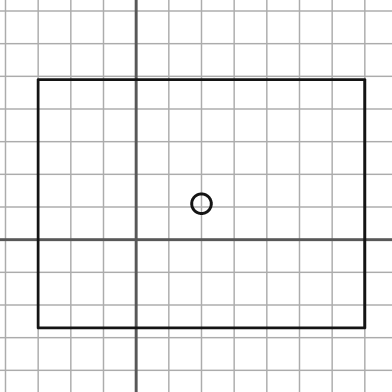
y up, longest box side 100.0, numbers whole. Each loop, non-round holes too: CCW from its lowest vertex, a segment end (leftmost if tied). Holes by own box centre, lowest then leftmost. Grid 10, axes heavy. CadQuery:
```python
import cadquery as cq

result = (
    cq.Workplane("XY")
    .moveTo(-30.0, -27.0)
    .lineTo(70.0, -27.0)
    .lineTo(70.0, 49.0)
    .lineTo(-30.0, 49.0)
    .close()
    .moveTo(20.0, 11.0)
    .circle(3.0)
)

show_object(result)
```